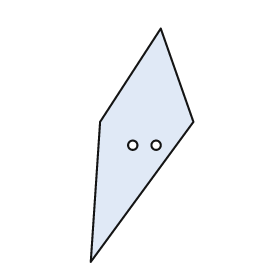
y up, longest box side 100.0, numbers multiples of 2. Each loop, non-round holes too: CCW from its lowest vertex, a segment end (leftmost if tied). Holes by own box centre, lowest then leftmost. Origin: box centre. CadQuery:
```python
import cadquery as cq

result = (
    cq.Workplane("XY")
    .moveTo(-22.0, -50.0)
    .lineTo(22.0, 10.0)
    .lineTo(8.0, 50.0)
    .lineTo(-18.0, 10.0)
    .close()
    .moveTo(-4.0, 0.0)
    .circle(2.0)
    .moveTo(6.0, 0.0)
    .circle(2.0)
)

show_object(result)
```